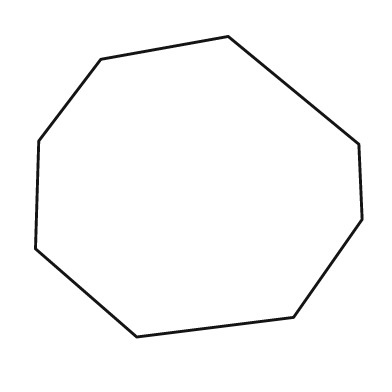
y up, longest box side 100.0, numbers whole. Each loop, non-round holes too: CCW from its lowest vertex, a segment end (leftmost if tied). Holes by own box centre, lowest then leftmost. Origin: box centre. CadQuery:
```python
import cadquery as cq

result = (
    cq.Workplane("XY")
    .moveTo(-19.0, -46.0)
    .lineTo(29.0, -40.0)
    .lineTo(50.0, -10.0)
    .lineTo(49.0, 13.0)
    .lineTo(9.0, 46.0)
    .lineTo(-30.0, 39.0)
    .lineTo(-49.0, 14.0)
    .lineTo(-50.0, -19.0)
    .close()
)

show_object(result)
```